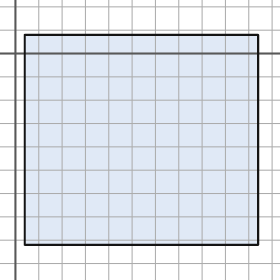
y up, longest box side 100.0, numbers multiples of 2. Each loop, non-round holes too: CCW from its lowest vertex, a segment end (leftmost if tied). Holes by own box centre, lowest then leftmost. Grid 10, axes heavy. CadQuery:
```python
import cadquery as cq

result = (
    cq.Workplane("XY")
    .moveTo(4.0, -82.0)
    .lineTo(104.0, -82.0)
    .lineTo(104.0, 8.0)
    .lineTo(4.0, 8.0)
    .close()
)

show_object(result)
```